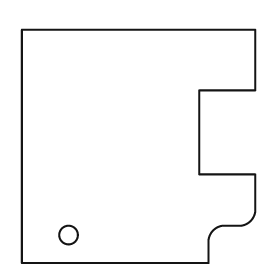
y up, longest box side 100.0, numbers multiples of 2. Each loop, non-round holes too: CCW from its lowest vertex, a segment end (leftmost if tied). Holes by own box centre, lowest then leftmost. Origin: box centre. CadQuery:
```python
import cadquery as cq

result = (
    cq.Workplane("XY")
    .moveTo(-50.0, -50.0)
    .lineTo(30.0, -50.0)
    .lineTo(30.0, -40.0)
    .threePointArc((32.0, -36.0), (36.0, -34.0))
    .lineTo(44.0, -34.0)
    .threePointArc((48.0, -32.0), (50.0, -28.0))
    .lineTo(50.0, -12.0)
    .lineTo(26.0, -12.0)
    .lineTo(26.0, 24.0)
    .lineTo(50.0, 24.0)
    .lineTo(50.0, 50.0)
    .lineTo(-50.0, 50.0)
    .close()
    .moveTo(-30.0, -38.0)
    .circle(4.0)
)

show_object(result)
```